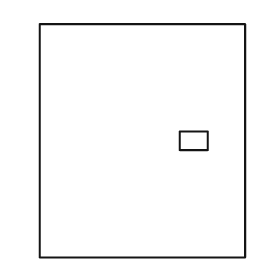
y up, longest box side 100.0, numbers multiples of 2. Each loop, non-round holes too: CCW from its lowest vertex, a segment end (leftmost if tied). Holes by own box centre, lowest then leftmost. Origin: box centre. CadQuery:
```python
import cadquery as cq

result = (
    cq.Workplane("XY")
    .moveTo(-44.0, -50.0)
    .lineTo(44.0, -50.0)
    .lineTo(44.0, 50.0)
    .lineTo(-44.0, 50.0)
    .close()
    .moveTo(16.0, -4.0)
    .lineTo(28.0, -4.0)
    .lineTo(28.0, 4.0)
    .lineTo(16.0, 4.0)
    .close()
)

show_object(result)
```